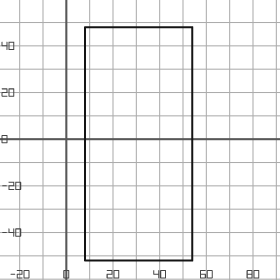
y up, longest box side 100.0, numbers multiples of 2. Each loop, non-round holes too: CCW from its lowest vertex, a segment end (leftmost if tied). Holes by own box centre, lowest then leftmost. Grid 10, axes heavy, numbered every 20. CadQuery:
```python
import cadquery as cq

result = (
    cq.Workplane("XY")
    .moveTo(8.0, -52.0)
    .lineTo(54.0, -52.0)
    .lineTo(54.0, 48.0)
    .lineTo(8.0, 48.0)
    .close()
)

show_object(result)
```